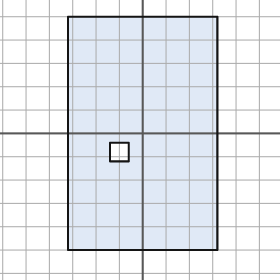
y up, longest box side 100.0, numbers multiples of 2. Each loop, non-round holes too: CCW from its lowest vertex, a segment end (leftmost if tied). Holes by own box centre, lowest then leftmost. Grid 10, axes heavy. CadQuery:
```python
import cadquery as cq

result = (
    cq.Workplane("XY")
    .moveTo(-32.0, -50.0)
    .lineTo(32.0, -50.0)
    .lineTo(32.0, 50.0)
    .lineTo(-32.0, 50.0)
    .close()
    .moveTo(-14.0, -12.0)
    .lineTo(-6.0, -12.0)
    .lineTo(-6.0, -4.0)
    .lineTo(-14.0, -4.0)
    .close()
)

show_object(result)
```